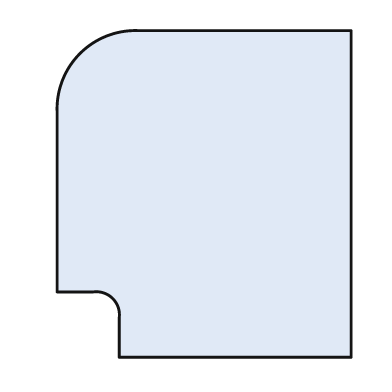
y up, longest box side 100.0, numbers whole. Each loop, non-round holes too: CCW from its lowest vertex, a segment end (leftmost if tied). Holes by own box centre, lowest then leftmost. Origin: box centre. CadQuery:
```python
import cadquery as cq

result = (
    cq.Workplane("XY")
    .moveTo(-26.0, -50.0)
    .lineTo(45.0, -50.0)
    .lineTo(45.0, 50.0)
    .lineTo(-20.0, 50.0)
    .threePointArc((-38.0, 43.0), (-45.0, 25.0))
    .lineTo(-45.0, -30.0)
    .lineTo(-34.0, -30.0)
    .threePointArc((-28.0, -32.0), (-26.0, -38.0))
    .close()
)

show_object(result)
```